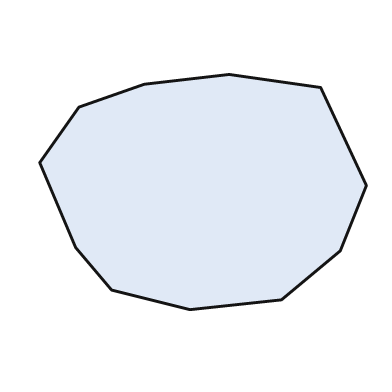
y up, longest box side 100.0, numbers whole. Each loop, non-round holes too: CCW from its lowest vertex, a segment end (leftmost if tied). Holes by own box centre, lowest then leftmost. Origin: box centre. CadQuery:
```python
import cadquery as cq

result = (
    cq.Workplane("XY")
    .moveTo(-4.0, -36.0)
    .lineTo(24.0, -33.0)
    .lineTo(42.0, -18.0)
    .lineTo(50.0, 2.0)
    .lineTo(36.0, 32.0)
    .lineTo(8.0, 36.0)
    .lineTo(-18.0, 33.0)
    .lineTo(-38.0, 26.0)
    .lineTo(-50.0, 9.0)
    .lineTo(-39.0, -17.0)
    .lineTo(-28.0, -30.0)
    .close()
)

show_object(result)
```